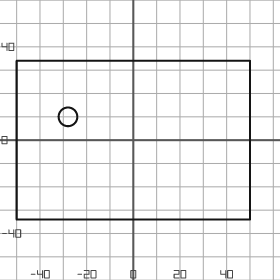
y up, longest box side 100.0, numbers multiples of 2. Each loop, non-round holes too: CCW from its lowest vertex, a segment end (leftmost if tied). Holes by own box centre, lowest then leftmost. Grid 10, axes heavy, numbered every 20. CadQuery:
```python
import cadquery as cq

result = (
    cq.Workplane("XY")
    .moveTo(-50.0, -34.0)
    .lineTo(50.0, -34.0)
    .lineTo(50.0, 34.0)
    .lineTo(-50.0, 34.0)
    .close()
    .moveTo(-28.0, 10.0)
    .circle(4.0)
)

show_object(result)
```